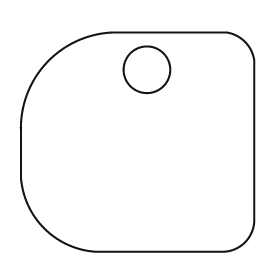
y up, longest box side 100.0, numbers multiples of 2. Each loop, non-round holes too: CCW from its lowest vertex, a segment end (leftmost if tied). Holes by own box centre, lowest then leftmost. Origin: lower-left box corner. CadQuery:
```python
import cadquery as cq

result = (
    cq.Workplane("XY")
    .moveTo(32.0, 0.0)
    .lineTo(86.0, 0.0)
    .threePointArc((96.0, 4.0), (100.0, 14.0))
    .lineTo(100.0, 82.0)
    .threePointArc((96.0, 90.0), (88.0, 94.0))
    .lineTo(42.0, 94.0)
    .threePointArc((12.0, 82.0), (0.0, 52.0))
    .lineTo(0.0, 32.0)
    .threePointArc((10.0, 10.0), (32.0, 0.0))
    .close()
    .moveTo(54.0, 78.0)
    .circle(10.0)
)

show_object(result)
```